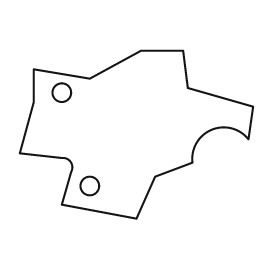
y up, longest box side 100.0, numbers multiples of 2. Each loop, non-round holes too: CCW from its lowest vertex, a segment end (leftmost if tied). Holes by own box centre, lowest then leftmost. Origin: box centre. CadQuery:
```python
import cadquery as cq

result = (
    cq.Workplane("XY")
    .moveTo(0.0, -36.0)
    .lineTo(8.0, -18.0)
    .lineTo(24.0, -12.0)
    .threePointArc((32.0, 2.0), (48.0, -2.0))
    .lineTo(50.0, 12.0)
    .lineTo(22.0, 20.0)
    .lineTo(20.0, 36.0)
    .lineTo(2.0, 36.0)
    .lineTo(-20.0, 24.0)
    .lineTo(-44.0, 28.0)
    .lineTo(-44.0, 14.0)
    .lineTo(-50.0, -8.0)
    .lineTo(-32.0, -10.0)
    .threePointArc((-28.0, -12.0), (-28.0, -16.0))
    .lineTo(-32.0, -30.0)
    .close()
    .moveTo(-20.0, -22.0)
    .circle(4.0)
    .moveTo(-32.0, 18.0)
    .circle(4.0)
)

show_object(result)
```